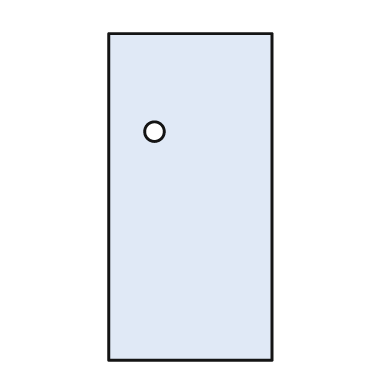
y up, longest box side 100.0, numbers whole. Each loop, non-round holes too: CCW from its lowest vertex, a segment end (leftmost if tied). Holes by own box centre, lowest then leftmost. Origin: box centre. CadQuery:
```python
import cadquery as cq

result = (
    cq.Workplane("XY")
    .moveTo(-25.0, -50.0)
    .lineTo(25.0, -50.0)
    .lineTo(25.0, 50.0)
    .lineTo(-25.0, 50.0)
    .close()
    .moveTo(-11.0, 20.0)
    .circle(3.0)
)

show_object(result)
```